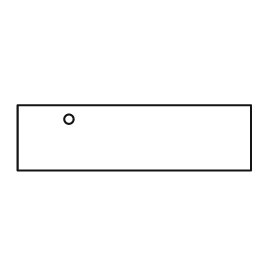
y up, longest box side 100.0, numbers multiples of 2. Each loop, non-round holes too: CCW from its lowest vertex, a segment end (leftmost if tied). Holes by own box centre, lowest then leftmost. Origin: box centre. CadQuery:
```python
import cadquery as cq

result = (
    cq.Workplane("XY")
    .moveTo(-50.0, -14.0)
    .lineTo(50.0, -14.0)
    .lineTo(50.0, 14.0)
    .lineTo(-50.0, 14.0)
    .close()
    .moveTo(-28.0, 8.0)
    .circle(2.0)
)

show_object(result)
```